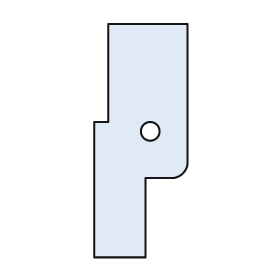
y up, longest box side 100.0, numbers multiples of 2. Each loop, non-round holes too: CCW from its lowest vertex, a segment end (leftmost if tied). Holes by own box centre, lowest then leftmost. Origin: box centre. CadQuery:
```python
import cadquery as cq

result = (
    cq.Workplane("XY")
    .moveTo(-20.0, -50.0)
    .lineTo(2.0, -50.0)
    .lineTo(2.0, -16.0)
    .lineTo(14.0, -16.0)
    .threePointArc((18.0, -14.0), (20.0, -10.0))
    .lineTo(20.0, 50.0)
    .lineTo(-14.0, 50.0)
    .lineTo(-14.0, 8.0)
    .lineTo(-20.0, 8.0)
    .close()
    .moveTo(4.0, 4.0)
    .circle(4.0)
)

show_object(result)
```